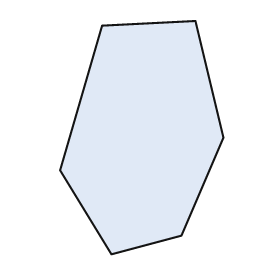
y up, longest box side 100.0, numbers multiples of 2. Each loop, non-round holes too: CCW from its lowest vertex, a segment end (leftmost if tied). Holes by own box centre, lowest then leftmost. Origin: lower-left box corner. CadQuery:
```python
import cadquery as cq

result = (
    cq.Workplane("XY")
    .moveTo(22.0, 0.0)
    .lineTo(52.0, 8.0)
    .lineTo(70.0, 50.0)
    .lineTo(58.0, 100.0)
    .lineTo(18.0, 98.0)
    .lineTo(0.0, 36.0)
    .close()
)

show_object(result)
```